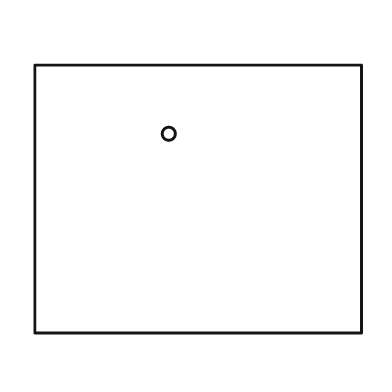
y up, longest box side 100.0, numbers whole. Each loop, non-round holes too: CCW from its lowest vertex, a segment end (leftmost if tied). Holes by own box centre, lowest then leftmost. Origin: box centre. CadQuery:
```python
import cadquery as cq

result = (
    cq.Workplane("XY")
    .moveTo(-50.0, -41.0)
    .lineTo(50.0, -41.0)
    .lineTo(50.0, 41.0)
    .lineTo(-50.0, 41.0)
    .close()
    .moveTo(-9.0, 20.0)
    .circle(2.0)
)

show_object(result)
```